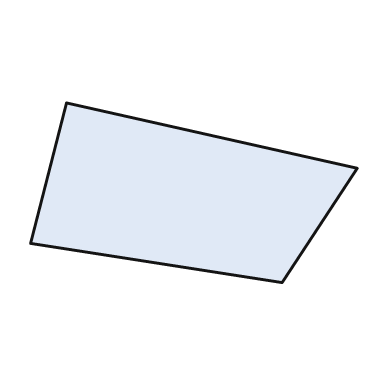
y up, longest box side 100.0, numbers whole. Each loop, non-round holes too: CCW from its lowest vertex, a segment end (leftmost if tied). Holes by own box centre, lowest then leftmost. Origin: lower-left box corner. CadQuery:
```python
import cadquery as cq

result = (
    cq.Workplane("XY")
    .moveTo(77.0, 0.0)
    .lineTo(100.0, 35.0)
    .lineTo(11.0, 55.0)
    .lineTo(0.0, 12.0)
    .close()
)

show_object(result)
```